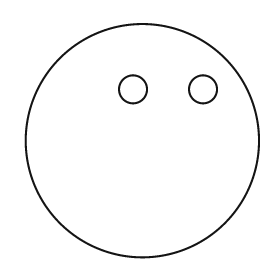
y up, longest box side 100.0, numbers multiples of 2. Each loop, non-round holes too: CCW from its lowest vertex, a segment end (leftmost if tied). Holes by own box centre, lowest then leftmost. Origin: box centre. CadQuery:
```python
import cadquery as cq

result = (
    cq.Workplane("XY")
    .moveTo(0.0, 0.0)
    .circle(50.0)
    .moveTo(-4.0, 22.0)
    .circle(6.0)
    .moveTo(26.0, 22.0)
    .circle(6.0)
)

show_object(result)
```